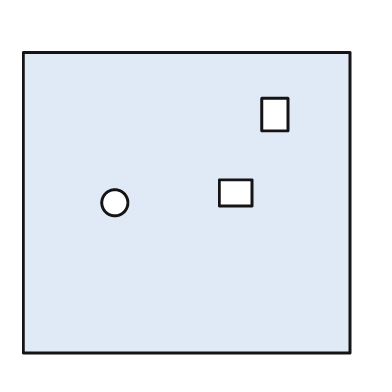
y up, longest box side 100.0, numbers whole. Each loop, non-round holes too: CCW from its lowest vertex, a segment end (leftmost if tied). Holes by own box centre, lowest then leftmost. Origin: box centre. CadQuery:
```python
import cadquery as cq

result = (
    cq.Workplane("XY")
    .moveTo(-50.0, -46.0)
    .lineTo(50.0, -46.0)
    .lineTo(50.0, 46.0)
    .lineTo(-50.0, 46.0)
    .close()
    .moveTo(-22.0, 0.0)
    .circle(4.0)
    .moveTo(10.0, -1.0)
    .lineTo(20.0, -1.0)
    .lineTo(20.0, 7.0)
    .lineTo(10.0, 7.0)
    .close()
    .moveTo(23.0, 22.0)
    .lineTo(31.0, 22.0)
    .lineTo(31.0, 32.0)
    .lineTo(23.0, 32.0)
    .close()
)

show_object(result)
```